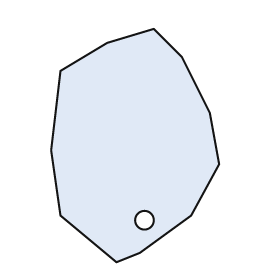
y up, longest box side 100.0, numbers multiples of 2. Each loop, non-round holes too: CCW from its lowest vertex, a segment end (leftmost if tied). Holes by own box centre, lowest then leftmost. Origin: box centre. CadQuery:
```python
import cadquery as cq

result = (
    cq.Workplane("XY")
    .moveTo(-8.0, -50.0)
    .lineTo(2.0, -46.0)
    .lineTo(24.0, -30.0)
    .lineTo(36.0, -8.0)
    .lineTo(32.0, 14.0)
    .lineTo(20.0, 38.0)
    .lineTo(8.0, 50.0)
    .lineTo(-12.0, 44.0)
    .lineTo(-32.0, 32.0)
    .lineTo(-36.0, -2.0)
    .lineTo(-32.0, -30.0)
    .close()
    .moveTo(4.0, -32.0)
    .circle(4.0)
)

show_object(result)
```